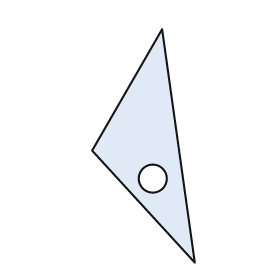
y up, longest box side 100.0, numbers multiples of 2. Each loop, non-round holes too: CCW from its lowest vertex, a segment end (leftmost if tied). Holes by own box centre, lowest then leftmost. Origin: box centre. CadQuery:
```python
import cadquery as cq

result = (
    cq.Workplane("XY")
    .moveTo(22.0, -50.0)
    .lineTo(8.0, 50.0)
    .lineTo(-22.0, -2.0)
    .close()
    .moveTo(4.0, -14.0)
    .circle(6.0)
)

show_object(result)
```